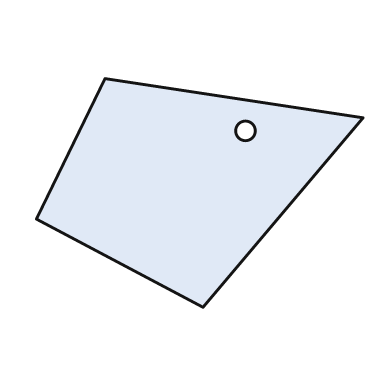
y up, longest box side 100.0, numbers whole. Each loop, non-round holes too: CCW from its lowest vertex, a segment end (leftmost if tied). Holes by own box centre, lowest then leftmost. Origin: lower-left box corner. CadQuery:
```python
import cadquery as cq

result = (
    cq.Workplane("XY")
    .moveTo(51.0, 0.0)
    .lineTo(100.0, 58.0)
    .lineTo(21.0, 70.0)
    .lineTo(0.0, 27.0)
    .close()
    .moveTo(64.0, 54.0)
    .circle(3.0)
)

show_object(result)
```